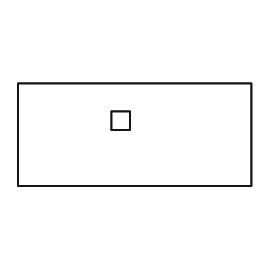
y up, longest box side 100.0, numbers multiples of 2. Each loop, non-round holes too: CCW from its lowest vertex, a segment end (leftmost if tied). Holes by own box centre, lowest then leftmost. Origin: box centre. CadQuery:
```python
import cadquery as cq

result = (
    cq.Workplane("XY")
    .moveTo(-50.0, -22.0)
    .lineTo(50.0, -22.0)
    .lineTo(50.0, 22.0)
    .lineTo(-50.0, 22.0)
    .close()
    .moveTo(-10.0, 2.0)
    .lineTo(-2.0, 2.0)
    .lineTo(-2.0, 10.0)
    .lineTo(-10.0, 10.0)
    .close()
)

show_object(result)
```